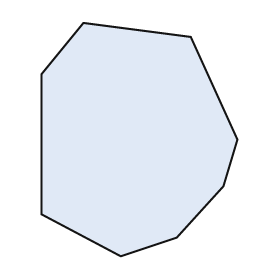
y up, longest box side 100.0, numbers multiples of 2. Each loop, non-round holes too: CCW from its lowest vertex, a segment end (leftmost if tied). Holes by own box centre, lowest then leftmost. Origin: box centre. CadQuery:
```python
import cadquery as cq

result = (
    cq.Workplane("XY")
    .moveTo(-8.0, -50.0)
    .lineTo(16.0, -42.0)
    .lineTo(36.0, -20.0)
    .lineTo(42.0, 0.0)
    .lineTo(22.0, 44.0)
    .lineTo(-24.0, 50.0)
    .lineTo(-42.0, 28.0)
    .lineTo(-42.0, -32.0)
    .close()
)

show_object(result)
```